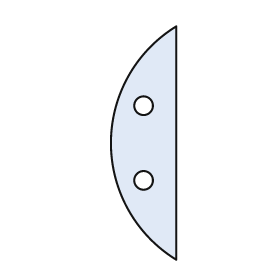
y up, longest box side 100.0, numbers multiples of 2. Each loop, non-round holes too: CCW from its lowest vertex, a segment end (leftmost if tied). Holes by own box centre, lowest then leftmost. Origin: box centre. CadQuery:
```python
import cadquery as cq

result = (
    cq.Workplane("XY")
    .moveTo(14.0, -50.0)
    .lineTo(14.0, 50.0)
    .threePointArc((-14.0, 0.0), (14.0, -50.0))
    .close()
    .moveTo(0.0, -16.0)
    .circle(4.0)
    .moveTo(0.0, 16.0)
    .circle(4.0)
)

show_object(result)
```